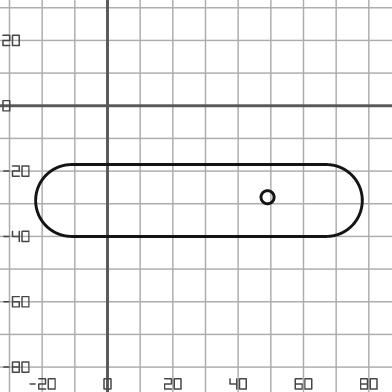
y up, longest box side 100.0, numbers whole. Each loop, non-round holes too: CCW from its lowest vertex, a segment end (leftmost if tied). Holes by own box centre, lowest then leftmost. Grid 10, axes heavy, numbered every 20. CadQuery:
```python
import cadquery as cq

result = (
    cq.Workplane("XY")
    .moveTo(-11.0, -40.0)
    .lineTo(67.0, -40.0)
    .threePointArc((78.0, -29.0), (67.0, -18.0))
    .lineTo(-11.0, -18.0)
    .threePointArc((-22.0, -29.0), (-11.0, -40.0))
    .close()
    .moveTo(49.0, -28.0)
    .circle(2.0)
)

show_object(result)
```